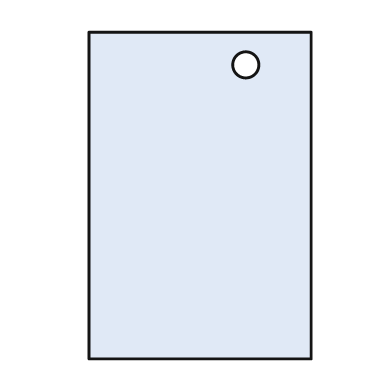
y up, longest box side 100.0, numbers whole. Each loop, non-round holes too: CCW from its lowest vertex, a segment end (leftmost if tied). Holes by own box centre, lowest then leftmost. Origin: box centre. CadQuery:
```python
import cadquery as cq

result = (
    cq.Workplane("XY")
    .moveTo(-34.0, -50.0)
    .lineTo(34.0, -50.0)
    .lineTo(34.0, 50.0)
    .lineTo(-34.0, 50.0)
    .close()
    .moveTo(14.0, 40.0)
    .circle(4.0)
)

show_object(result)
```